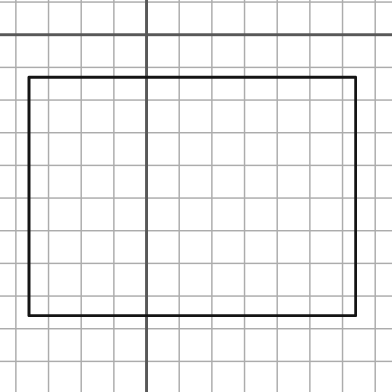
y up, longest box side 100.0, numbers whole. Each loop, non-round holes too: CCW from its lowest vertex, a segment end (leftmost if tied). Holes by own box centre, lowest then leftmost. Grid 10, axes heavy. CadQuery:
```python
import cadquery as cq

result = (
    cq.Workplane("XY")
    .moveTo(-36.0, -86.0)
    .lineTo(64.0, -86.0)
    .lineTo(64.0, -13.0)
    .lineTo(-36.0, -13.0)
    .close()
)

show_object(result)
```